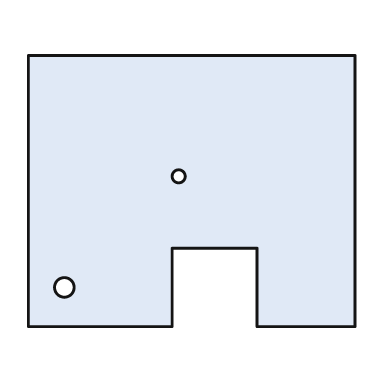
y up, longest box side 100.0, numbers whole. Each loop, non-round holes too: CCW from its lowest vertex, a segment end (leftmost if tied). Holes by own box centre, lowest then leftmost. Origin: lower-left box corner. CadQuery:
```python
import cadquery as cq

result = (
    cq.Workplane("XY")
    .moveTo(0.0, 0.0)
    .lineTo(44.0, 0.0)
    .lineTo(44.0, 24.0)
    .lineTo(70.0, 24.0)
    .lineTo(70.0, 0.0)
    .lineTo(100.0, 0.0)
    .lineTo(100.0, 83.0)
    .lineTo(0.0, 83.0)
    .close()
    .moveTo(11.0, 12.0)
    .circle(3.0)
    .moveTo(46.0, 46.0)
    .circle(2.0)
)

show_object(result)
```